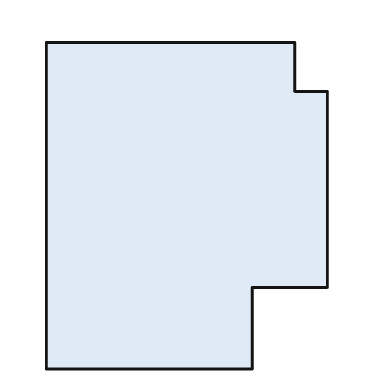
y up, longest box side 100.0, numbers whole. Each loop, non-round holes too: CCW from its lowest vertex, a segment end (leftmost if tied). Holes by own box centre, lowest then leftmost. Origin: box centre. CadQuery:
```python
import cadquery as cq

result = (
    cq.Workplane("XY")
    .moveTo(-43.0, -50.0)
    .lineTo(20.0, -50.0)
    .lineTo(20.0, -25.0)
    .lineTo(43.0, -25.0)
    .lineTo(43.0, 35.0)
    .lineTo(33.0, 35.0)
    .lineTo(33.0, 50.0)
    .lineTo(-43.0, 50.0)
    .close()
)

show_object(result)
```